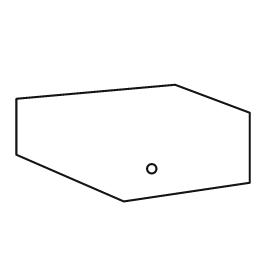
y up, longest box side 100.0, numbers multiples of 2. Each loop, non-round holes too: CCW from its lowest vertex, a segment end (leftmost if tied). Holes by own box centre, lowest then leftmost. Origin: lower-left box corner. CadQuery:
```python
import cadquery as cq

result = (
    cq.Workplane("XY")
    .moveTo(46.0, 0.0)
    .lineTo(100.0, 8.0)
    .lineTo(100.0, 38.0)
    .lineTo(68.0, 50.0)
    .lineTo(0.0, 44.0)
    .lineTo(0.0, 20.0)
    .close()
    .moveTo(58.0, 14.0)
    .circle(2.0)
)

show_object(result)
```